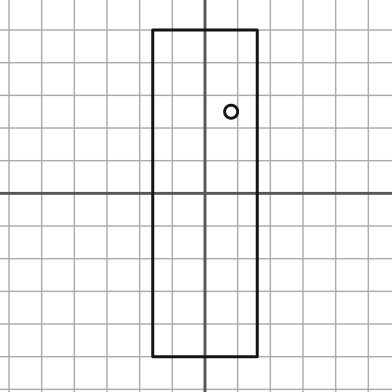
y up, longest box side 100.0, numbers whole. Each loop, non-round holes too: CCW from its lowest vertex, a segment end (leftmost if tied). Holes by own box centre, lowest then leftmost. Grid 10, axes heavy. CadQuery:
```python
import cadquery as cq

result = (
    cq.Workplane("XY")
    .moveTo(-16.0, -50.0)
    .lineTo(16.0, -50.0)
    .lineTo(16.0, 50.0)
    .lineTo(-16.0, 50.0)
    .close()
    .moveTo(8.0, 25.0)
    .circle(2.0)
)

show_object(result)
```